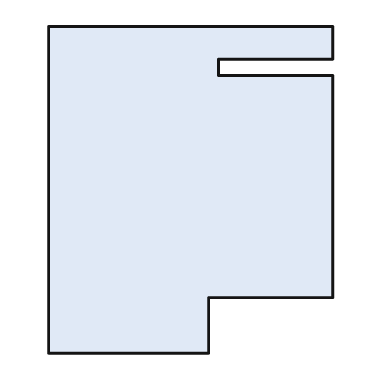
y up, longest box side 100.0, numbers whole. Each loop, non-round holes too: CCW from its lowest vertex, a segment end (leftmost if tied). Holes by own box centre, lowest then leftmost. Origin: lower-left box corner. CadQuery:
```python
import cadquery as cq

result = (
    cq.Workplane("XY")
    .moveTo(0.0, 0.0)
    .lineTo(49.0, 0.0)
    .lineTo(49.0, 17.0)
    .lineTo(87.0, 17.0)
    .lineTo(87.0, 85.0)
    .lineTo(52.0, 85.0)
    .lineTo(52.0, 90.0)
    .lineTo(87.0, 90.0)
    .lineTo(87.0, 100.0)
    .lineTo(0.0, 100.0)
    .close()
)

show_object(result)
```